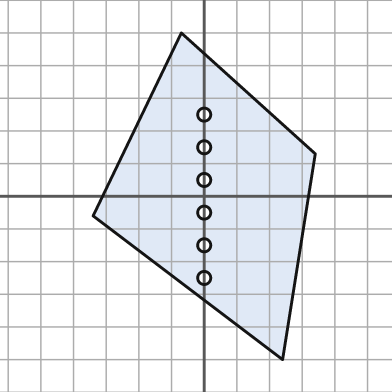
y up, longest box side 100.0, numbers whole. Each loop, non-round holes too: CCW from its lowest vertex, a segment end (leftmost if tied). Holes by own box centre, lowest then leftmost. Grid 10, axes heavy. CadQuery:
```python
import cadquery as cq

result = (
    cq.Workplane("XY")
    .moveTo(24.0, -50.0)
    .lineTo(34.0, 13.0)
    .lineTo(-7.0, 50.0)
    .lineTo(-34.0, -6.0)
    .close()
    .moveTo(0.0, -25.0)
    .circle(2.0)
    .moveTo(0.0, -15.0)
    .circle(2.0)
    .moveTo(0.0, -5.0)
    .circle(2.0)
    .moveTo(0.0, 5.0)
    .circle(2.0)
    .moveTo(0.0, 15.0)
    .circle(2.0)
    .moveTo(0.0, 25.0)
    .circle(2.0)
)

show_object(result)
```